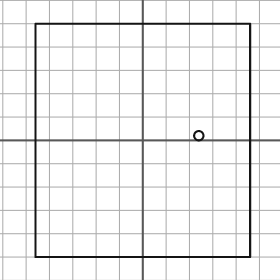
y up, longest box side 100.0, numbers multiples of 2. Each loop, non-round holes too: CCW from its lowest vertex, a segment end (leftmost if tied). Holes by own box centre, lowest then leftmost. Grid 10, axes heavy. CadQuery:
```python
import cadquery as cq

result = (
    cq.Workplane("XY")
    .moveTo(-46.0, -50.0)
    .lineTo(46.0, -50.0)
    .lineTo(46.0, 50.0)
    .lineTo(-46.0, 50.0)
    .close()
    .moveTo(24.0, 2.0)
    .circle(2.0)
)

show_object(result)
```